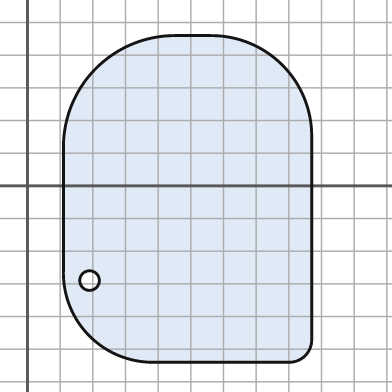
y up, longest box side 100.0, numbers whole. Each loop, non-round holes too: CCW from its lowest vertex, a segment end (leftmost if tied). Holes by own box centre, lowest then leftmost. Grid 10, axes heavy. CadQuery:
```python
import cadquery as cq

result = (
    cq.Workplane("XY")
    .moveTo(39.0, -54.0)
    .lineTo(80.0, -54.0)
    .threePointArc((85.0, -52.0), (87.0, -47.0))
    .lineTo(87.0, 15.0)
    .threePointArc((78.0, 37.0), (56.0, 46.0))
    .lineTo(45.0, 46.0)
    .threePointArc((21.0, 36.0), (11.0, 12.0))
    .lineTo(11.0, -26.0)
    .threePointArc((19.0, -46.0), (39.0, -54.0))
    .close()
    .moveTo(19.0, -29.0)
    .circle(3.0)
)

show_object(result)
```